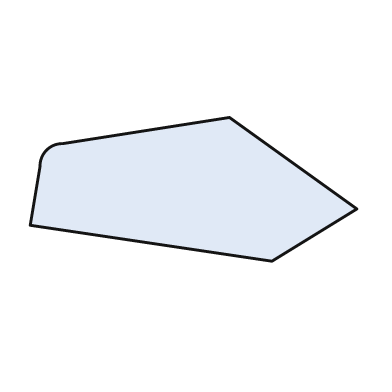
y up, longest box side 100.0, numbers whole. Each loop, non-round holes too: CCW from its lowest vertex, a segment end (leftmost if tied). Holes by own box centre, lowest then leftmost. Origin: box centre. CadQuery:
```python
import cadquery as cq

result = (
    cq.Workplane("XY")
    .moveTo(24.0, -22.0)
    .lineTo(50.0, -6.0)
    .lineTo(11.0, 22.0)
    .lineTo(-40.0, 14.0)
    .threePointArc((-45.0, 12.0), (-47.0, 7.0))
    .lineTo(-50.0, -11.0)
    .close()
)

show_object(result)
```